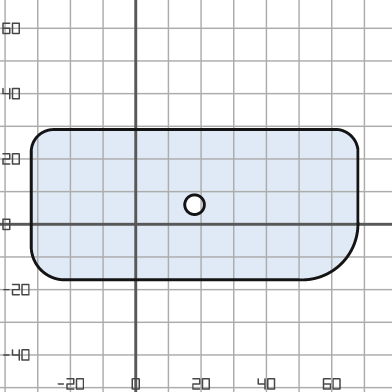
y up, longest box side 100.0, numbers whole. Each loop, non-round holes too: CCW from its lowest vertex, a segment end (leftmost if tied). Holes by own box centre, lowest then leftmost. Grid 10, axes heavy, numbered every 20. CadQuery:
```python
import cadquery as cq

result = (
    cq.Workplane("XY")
    .moveTo(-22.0, -17.0)
    .lineTo(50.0, -17.0)
    .threePointArc((63.0, -12.0), (68.0, 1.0))
    .lineTo(68.0, 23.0)
    .threePointArc((66.0, 27.0), (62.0, 29.0))
    .lineTo(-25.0, 29.0)
    .threePointArc((-30.0, 27.0), (-32.0, 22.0))
    .lineTo(-32.0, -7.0)
    .threePointArc((-29.0, -14.0), (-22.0, -17.0))
    .close()
    .moveTo(18.0, 6.0)
    .circle(3.0)
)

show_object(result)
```